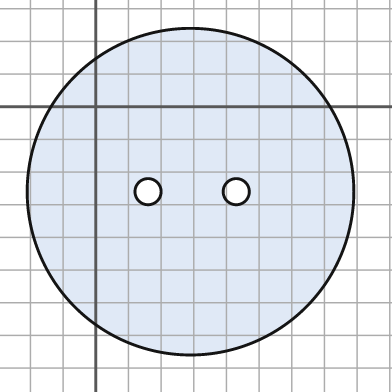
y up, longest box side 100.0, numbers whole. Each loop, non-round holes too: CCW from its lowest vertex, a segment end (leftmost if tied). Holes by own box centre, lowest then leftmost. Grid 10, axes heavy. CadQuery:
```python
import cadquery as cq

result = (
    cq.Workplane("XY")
    .moveTo(29.0, -26.0)
    .circle(50.0)
    .moveTo(16.0, -26.0)
    .circle(4.0)
    .moveTo(43.0, -26.0)
    .circle(4.0)
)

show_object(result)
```